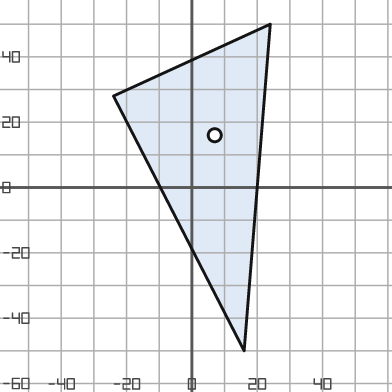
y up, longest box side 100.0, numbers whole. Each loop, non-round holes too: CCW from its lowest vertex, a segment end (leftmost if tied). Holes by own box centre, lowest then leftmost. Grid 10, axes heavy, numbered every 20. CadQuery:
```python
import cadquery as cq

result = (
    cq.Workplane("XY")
    .moveTo(16.0, -50.0)
    .lineTo(24.0, 50.0)
    .lineTo(-24.0, 28.0)
    .close()
    .moveTo(7.0, 16.0)
    .circle(2.0)
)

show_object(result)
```